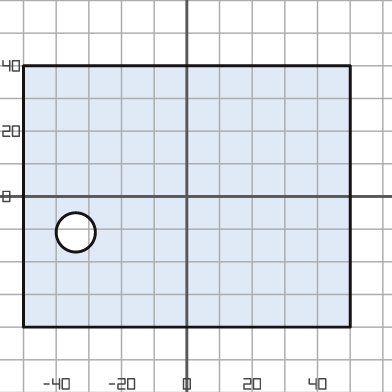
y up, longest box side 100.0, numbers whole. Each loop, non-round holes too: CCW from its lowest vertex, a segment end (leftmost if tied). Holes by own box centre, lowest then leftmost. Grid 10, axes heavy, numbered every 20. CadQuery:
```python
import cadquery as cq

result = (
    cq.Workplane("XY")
    .moveTo(-50.0, -40.0)
    .lineTo(50.0, -40.0)
    .lineTo(50.0, 40.0)
    .lineTo(-50.0, 40.0)
    .close()
    .moveTo(-34.0, -11.0)
    .circle(6.0)
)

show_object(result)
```